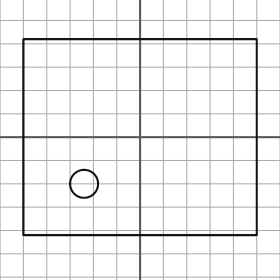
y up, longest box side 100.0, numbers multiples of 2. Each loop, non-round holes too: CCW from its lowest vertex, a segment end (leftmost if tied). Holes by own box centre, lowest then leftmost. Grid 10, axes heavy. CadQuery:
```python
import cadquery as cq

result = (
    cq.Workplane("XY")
    .moveTo(-50.0, -42.0)
    .lineTo(50.0, -42.0)
    .lineTo(50.0, 42.0)
    .lineTo(-50.0, 42.0)
    .close()
    .moveTo(-24.0, -20.0)
    .circle(6.0)
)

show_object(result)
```